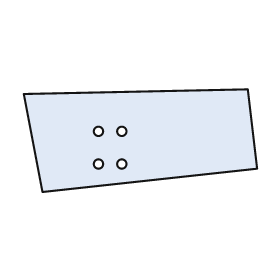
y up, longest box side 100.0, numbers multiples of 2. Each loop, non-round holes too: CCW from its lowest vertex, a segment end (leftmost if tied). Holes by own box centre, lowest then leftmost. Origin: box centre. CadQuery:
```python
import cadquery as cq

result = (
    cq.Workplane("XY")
    .moveTo(-42.0, -22.0)
    .lineTo(50.0, -12.0)
    .lineTo(46.0, 22.0)
    .lineTo(-50.0, 20.0)
    .close()
    .moveTo(-18.0, -10.0)
    .circle(2.0)
    .moveTo(-8.0, -10.0)
    .circle(2.0)
    .moveTo(-18.0, 4.0)
    .circle(2.0)
    .moveTo(-8.0, 4.0)
    .circle(2.0)
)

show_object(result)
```